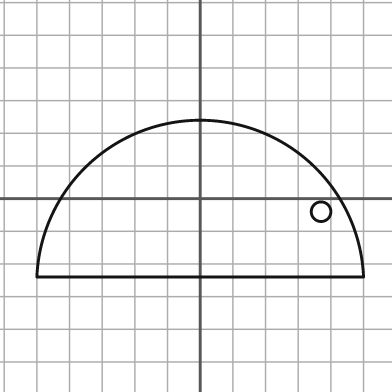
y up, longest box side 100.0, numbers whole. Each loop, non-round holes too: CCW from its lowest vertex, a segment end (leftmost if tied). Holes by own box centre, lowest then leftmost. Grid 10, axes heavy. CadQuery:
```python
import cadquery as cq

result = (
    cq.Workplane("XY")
    .moveTo(-50.0, -24.0)
    .lineTo(50.0, -24.0)
    .threePointArc((0.0, 24.0), (-50.0, -24.0))
    .close()
    .moveTo(37.0, -4.0)
    .circle(3.0)
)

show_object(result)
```